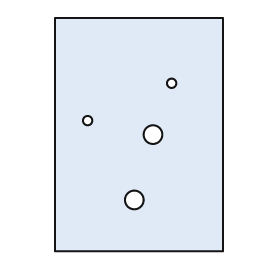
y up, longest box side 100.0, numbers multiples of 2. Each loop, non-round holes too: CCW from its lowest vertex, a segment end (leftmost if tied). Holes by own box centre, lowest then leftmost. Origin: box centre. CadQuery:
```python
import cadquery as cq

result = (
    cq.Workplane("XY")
    .moveTo(-36.0, -50.0)
    .lineTo(36.0, -50.0)
    .lineTo(36.0, 50.0)
    .lineTo(-36.0, 50.0)
    .close()
    .moveTo(-2.0, -28.0)
    .circle(4.0)
    .moveTo(6.0, 0.0)
    .circle(4.0)
    .moveTo(-22.0, 6.0)
    .circle(2.0)
    .moveTo(14.0, 22.0)
    .circle(2.0)
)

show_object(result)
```